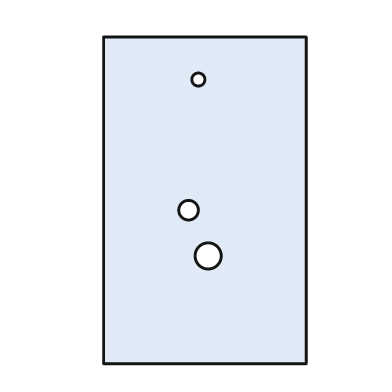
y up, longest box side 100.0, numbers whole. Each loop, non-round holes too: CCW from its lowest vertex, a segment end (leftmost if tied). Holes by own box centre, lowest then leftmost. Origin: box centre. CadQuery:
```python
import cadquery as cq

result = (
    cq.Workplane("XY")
    .moveTo(-31.0, -50.0)
    .lineTo(31.0, -50.0)
    .lineTo(31.0, 50.0)
    .lineTo(-31.0, 50.0)
    .close()
    .moveTo(1.0, -17.0)
    .circle(4.0)
    .moveTo(-5.0, -3.0)
    .circle(3.0)
    .moveTo(-2.0, 37.0)
    .circle(2.0)
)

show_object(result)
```